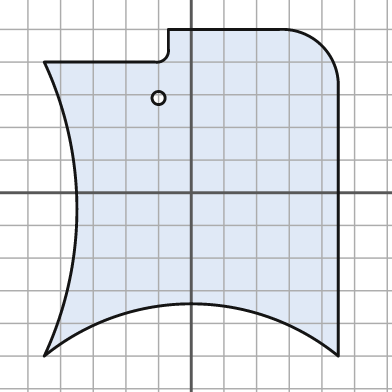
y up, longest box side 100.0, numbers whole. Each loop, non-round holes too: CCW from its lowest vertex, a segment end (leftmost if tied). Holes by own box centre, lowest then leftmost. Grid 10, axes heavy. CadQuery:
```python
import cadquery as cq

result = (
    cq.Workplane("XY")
    .moveTo(-45.0, -50.0)
    .threePointArc((0.0, -34.0), (45.0, -50.0))
    .lineTo(45.0, 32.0)
    .threePointArc((40.0, 45.0), (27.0, 50.0))
    .lineTo(-7.0, 50.0)
    .lineTo(-7.0, 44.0)
    .threePointArc((-8.0, 41.0), (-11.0, 40.0))
    .lineTo(-45.0, 40.0)
    .threePointArc((-35.0, -5.0), (-45.0, -50.0))
    .close()
    .moveTo(-10.0, 29.0)
    .circle(2.0)
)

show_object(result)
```